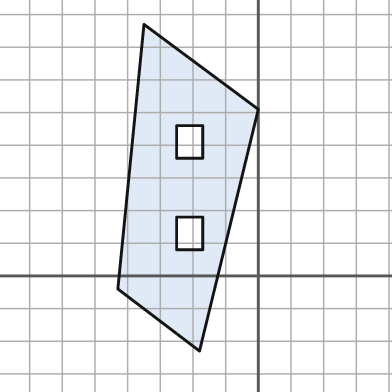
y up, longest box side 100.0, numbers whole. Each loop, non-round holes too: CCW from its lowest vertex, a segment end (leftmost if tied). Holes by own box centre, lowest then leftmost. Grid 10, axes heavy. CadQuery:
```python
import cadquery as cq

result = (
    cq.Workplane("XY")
    .moveTo(-18.0, -23.0)
    .lineTo(0.0, 51.0)
    .lineTo(-35.0, 77.0)
    .lineTo(-43.0, -4.0)
    .close()
    .moveTo(-25.0, 8.0)
    .lineTo(-17.0, 8.0)
    .lineTo(-17.0, 18.0)
    .lineTo(-25.0, 18.0)
    .close()
    .moveTo(-25.0, 36.0)
    .lineTo(-17.0, 36.0)
    .lineTo(-17.0, 46.0)
    .lineTo(-25.0, 46.0)
    .close()
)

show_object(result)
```